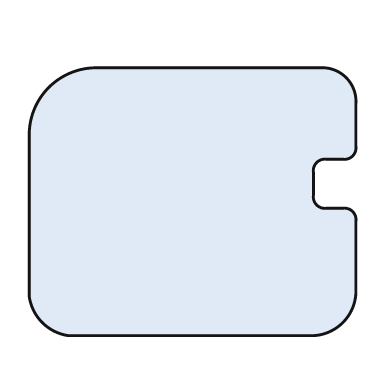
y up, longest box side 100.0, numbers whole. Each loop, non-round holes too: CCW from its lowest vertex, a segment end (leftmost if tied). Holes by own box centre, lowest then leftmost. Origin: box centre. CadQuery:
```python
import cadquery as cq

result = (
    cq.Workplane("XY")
    .moveTo(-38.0, -41.0)
    .lineTo(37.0, -41.0)
    .threePointArc((46.0, -37.0), (50.0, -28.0))
    .lineTo(50.0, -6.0)
    .threePointArc((49.0, -3.0), (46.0, -2.0))
    .lineTo(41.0, -2.0)
    .threePointArc((38.0, -1.0), (37.0, 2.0))
    .lineTo(37.0, 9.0)
    .threePointArc((38.0, 12.0), (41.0, 13.0))
    .lineTo(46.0, 13.0)
    .threePointArc((49.0, 14.0), (50.0, 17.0))
    .lineTo(50.0, 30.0)
    .threePointArc((47.0, 38.0), (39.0, 41.0))
    .lineTo(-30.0, 41.0)
    .threePointArc((-44.0, 35.0), (-50.0, 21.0))
    .lineTo(-50.0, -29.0)
    .threePointArc((-46.0, -37.0), (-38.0, -41.0))
    .close()
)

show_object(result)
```